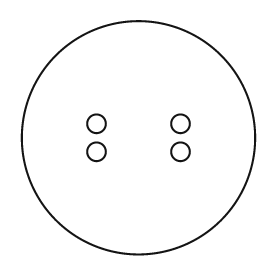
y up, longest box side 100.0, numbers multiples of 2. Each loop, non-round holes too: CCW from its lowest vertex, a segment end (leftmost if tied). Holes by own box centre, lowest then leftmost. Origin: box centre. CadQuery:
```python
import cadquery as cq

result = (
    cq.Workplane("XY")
    .moveTo(0.0, 0.0)
    .circle(50.0)
    .moveTo(-18.0, -6.0)
    .circle(4.0)
    .moveTo(18.0, -6.0)
    .circle(4.0)
    .moveTo(-18.0, 6.0)
    .circle(4.0)
    .moveTo(18.0, 6.0)
    .circle(4.0)
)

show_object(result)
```